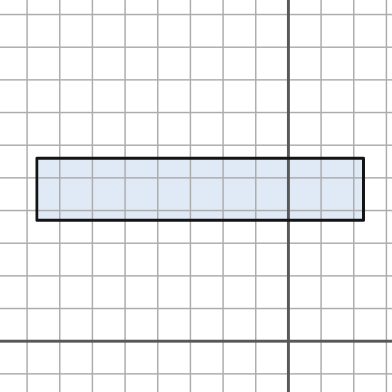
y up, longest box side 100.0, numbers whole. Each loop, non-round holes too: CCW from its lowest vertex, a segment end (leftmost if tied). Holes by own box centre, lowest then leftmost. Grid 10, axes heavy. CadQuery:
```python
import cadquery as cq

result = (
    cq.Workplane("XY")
    .moveTo(-77.0, 37.0)
    .lineTo(23.0, 37.0)
    .lineTo(23.0, 56.0)
    .lineTo(-77.0, 56.0)
    .close()
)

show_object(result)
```